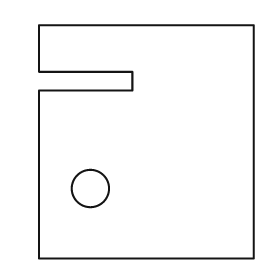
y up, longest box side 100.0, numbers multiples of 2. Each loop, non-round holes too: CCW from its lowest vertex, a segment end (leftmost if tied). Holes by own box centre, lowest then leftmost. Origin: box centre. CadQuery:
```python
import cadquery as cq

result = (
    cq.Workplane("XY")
    .moveTo(-46.0, -50.0)
    .lineTo(46.0, -50.0)
    .lineTo(46.0, 50.0)
    .lineTo(-46.0, 50.0)
    .lineTo(-46.0, 30.0)
    .lineTo(-6.0, 30.0)
    .lineTo(-6.0, 22.0)
    .lineTo(-46.0, 22.0)
    .close()
    .moveTo(-24.0, -20.0)
    .circle(8.0)
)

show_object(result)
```